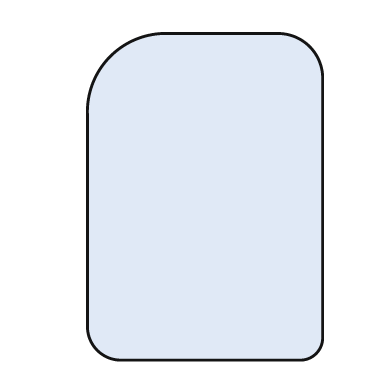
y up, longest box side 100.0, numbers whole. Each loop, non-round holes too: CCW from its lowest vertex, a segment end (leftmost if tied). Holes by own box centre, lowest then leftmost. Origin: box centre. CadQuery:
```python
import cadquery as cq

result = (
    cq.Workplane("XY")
    .moveTo(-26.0, -50.0)
    .lineTo(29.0, -50.0)
    .threePointArc((34.0, -48.0), (36.0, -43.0))
    .lineTo(36.0, 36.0)
    .threePointArc((32.0, 46.0), (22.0, 50.0))
    .lineTo(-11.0, 50.0)
    .threePointArc((-29.0, 43.0), (-36.0, 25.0))
    .lineTo(-36.0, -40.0)
    .threePointArc((-33.0, -47.0), (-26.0, -50.0))
    .close()
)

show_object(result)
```